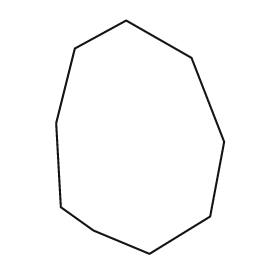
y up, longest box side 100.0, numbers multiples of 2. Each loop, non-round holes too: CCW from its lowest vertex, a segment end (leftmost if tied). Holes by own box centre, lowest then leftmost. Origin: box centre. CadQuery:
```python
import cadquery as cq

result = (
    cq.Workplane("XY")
    .moveTo(4.0, -50.0)
    .lineTo(30.0, -34.0)
    .lineTo(36.0, -2.0)
    .lineTo(22.0, 34.0)
    .lineTo(-6.0, 50.0)
    .lineTo(-28.0, 38.0)
    .lineTo(-36.0, 6.0)
    .lineTo(-34.0, -30.0)
    .lineTo(-20.0, -40.0)
    .close()
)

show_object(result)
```